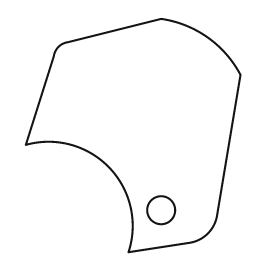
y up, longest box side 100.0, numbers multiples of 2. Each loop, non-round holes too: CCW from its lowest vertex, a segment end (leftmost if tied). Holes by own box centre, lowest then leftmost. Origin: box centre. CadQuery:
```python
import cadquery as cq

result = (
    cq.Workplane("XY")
    .moveTo(-2.0, -50.0)
    .lineTo(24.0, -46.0)
    .threePointArc((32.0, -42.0), (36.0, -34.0))
    .lineTo(46.0, 26.0)
    .threePointArc((32.0, 42.0), (12.0, 50.0))
    .lineTo(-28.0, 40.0)
    .threePointArc((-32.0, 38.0), (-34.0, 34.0))
    .lineTo(-46.0, -4.0)
    .threePointArc((-10.0, -14.0), (-2.0, -50.0))
    .close()
    .moveTo(12.0, -32.0)
    .circle(6.0)
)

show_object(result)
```